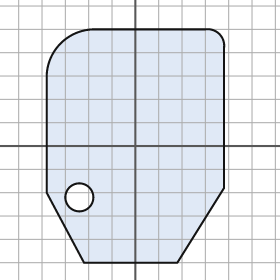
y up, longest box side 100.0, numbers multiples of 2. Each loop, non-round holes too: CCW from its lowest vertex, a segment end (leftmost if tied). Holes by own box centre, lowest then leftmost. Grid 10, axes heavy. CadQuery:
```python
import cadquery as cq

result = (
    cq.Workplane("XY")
    .moveTo(-22.0, -50.0)
    .lineTo(18.0, -50.0)
    .lineTo(38.0, -18.0)
    .lineTo(38.0, 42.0)
    .threePointArc((36.0, 48.0), (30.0, 50.0))
    .lineTo(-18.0, 50.0)
    .threePointArc((-32.0, 44.0), (-38.0, 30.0))
    .lineTo(-38.0, -20.0)
    .close()
    .moveTo(-24.0, -22.0)
    .circle(6.0)
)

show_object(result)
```